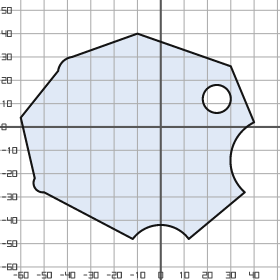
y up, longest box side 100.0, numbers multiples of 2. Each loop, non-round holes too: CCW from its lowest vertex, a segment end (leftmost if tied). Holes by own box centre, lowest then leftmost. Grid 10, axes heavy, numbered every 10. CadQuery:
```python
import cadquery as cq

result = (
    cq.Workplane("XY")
    .moveTo(-12.0, -48.0)
    .threePointArc((0.0, -42.0), (12.0, -48.0))
    .lineTo(36.0, -28.0)
    .threePointArc((30.0, -12.0), (40.0, 2.0))
    .lineTo(30.0, 26.0)
    .lineTo(-10.0, 40.0)
    .lineTo(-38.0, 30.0)
    .threePointArc((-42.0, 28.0), (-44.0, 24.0))
    .lineTo(-60.0, 4.0)
    .lineTo(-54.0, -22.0)
    .threePointArc((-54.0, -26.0), (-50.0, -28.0))
    .close()
    .moveTo(24.0, 12.0)
    .circle(6.0)
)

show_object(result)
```